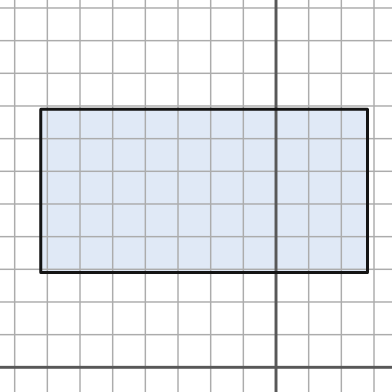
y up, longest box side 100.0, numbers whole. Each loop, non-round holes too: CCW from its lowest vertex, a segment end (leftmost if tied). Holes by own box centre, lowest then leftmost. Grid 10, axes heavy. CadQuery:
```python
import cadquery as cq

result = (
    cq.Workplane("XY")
    .moveTo(-72.0, 29.0)
    .lineTo(28.0, 29.0)
    .lineTo(28.0, 79.0)
    .lineTo(-72.0, 79.0)
    .close()
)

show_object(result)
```